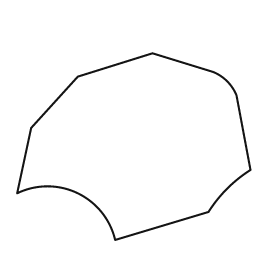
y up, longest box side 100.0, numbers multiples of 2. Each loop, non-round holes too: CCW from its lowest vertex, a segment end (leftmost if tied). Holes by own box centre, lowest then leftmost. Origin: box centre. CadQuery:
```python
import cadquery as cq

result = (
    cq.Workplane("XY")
    .moveTo(-8.0, -40.0)
    .lineTo(32.0, -28.0)
    .threePointArc((40.0, -18.0), (50.0, -10.0))
    .lineTo(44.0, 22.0)
    .threePointArc((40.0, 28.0), (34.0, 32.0))
    .lineTo(8.0, 40.0)
    .lineTo(-24.0, 30.0)
    .lineTo(-44.0, 8.0)
    .lineTo(-50.0, -20.0)
    .threePointArc((-24.0, -20.0), (-8.0, -40.0))
    .close()
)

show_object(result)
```